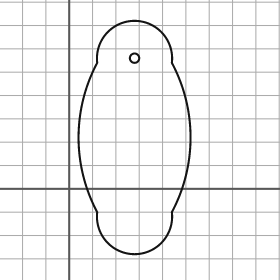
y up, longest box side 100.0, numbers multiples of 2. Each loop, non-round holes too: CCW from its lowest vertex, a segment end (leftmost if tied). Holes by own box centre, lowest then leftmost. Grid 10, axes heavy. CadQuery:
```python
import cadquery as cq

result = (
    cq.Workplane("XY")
    .moveTo(12.0, -10.0)
    .threePointArc((28.0, -28.0), (44.0, -10.0))
    .threePointArc((52.0, 22.0), (44.0, 54.0))
    .threePointArc((28.0, 72.0), (12.0, 54.0))
    .threePointArc((4.0, 22.0), (12.0, -10.0))
    .close()
    .moveTo(28.0, 56.0)
    .circle(2.0)
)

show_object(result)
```